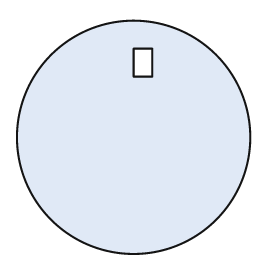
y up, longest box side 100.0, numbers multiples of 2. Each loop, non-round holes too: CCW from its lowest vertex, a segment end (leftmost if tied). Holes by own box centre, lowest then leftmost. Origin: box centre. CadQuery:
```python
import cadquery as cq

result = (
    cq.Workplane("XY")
    .moveTo(0.0, 0.0)
    .circle(50.0)
    .moveTo(0.0, 26.0)
    .lineTo(8.0, 26.0)
    .lineTo(8.0, 38.0)
    .lineTo(0.0, 38.0)
    .close()
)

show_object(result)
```